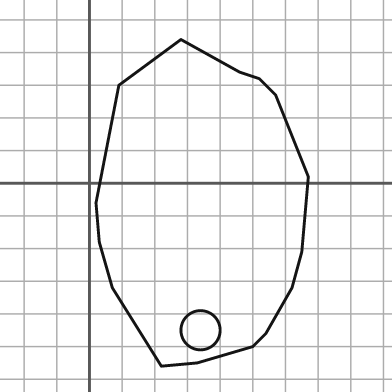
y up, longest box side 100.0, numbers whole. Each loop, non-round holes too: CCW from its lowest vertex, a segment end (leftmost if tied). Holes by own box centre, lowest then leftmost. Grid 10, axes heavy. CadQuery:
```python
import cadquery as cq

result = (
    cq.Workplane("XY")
    .moveTo(22.0, -56.0)
    .lineTo(33.0, -55.0)
    .lineTo(50.0, -50.0)
    .lineTo(54.0, -46.0)
    .lineTo(62.0, -32.0)
    .lineTo(65.0, -21.0)
    .lineTo(67.0, 2.0)
    .lineTo(57.0, 27.0)
    .lineTo(52.0, 32.0)
    .lineTo(46.0, 34.0)
    .lineTo(28.0, 44.0)
    .lineTo(9.0, 30.0)
    .lineTo(2.0, -6.0)
    .lineTo(3.0, -18.0)
    .lineTo(7.0, -32.0)
    .close()
    .moveTo(34.0, -45.0)
    .circle(6.0)
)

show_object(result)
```